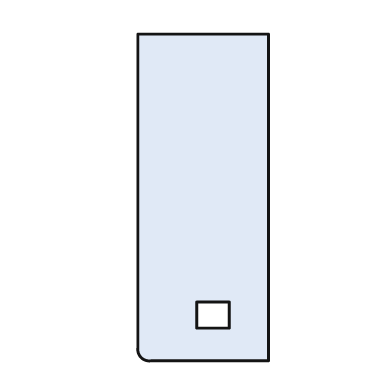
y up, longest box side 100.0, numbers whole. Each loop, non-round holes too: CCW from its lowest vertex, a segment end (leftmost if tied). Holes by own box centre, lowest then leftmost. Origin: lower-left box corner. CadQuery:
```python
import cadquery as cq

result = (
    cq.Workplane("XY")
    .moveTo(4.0, 0.0)
    .lineTo(40.0, 0.0)
    .lineTo(40.0, 100.0)
    .lineTo(0.0, 100.0)
    .lineTo(0.0, 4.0)
    .threePointArc((1.0, 1.0), (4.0, 0.0))
    .close()
    .moveTo(18.0, 10.0)
    .lineTo(28.0, 10.0)
    .lineTo(28.0, 18.0)
    .lineTo(18.0, 18.0)
    .close()
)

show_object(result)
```